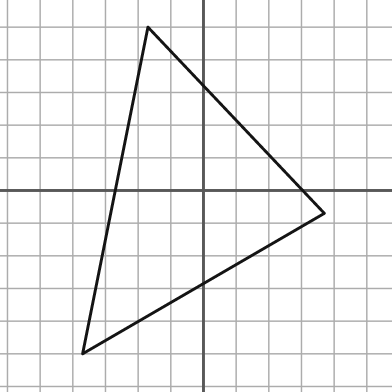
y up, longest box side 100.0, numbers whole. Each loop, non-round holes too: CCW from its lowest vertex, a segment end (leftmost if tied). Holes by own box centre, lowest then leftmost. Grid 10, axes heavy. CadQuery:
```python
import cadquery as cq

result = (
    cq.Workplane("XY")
    .moveTo(-37.0, -50.0)
    .lineTo(37.0, -7.0)
    .lineTo(-17.0, 50.0)
    .close()
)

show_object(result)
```